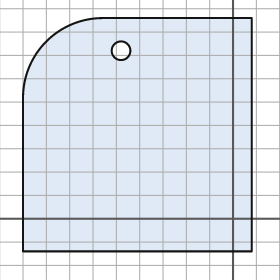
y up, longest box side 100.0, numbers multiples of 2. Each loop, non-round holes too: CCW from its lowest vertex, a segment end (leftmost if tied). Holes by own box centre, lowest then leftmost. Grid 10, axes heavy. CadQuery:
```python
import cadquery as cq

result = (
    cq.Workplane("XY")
    .moveTo(-90.0, -14.0)
    .lineTo(8.0, -14.0)
    .lineTo(8.0, 86.0)
    .lineTo(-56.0, 86.0)
    .threePointArc((-80.0, 76.0), (-90.0, 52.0))
    .close()
    .moveTo(-48.0, 72.0)
    .circle(4.0)
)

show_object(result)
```